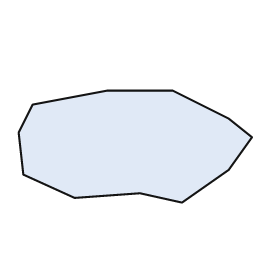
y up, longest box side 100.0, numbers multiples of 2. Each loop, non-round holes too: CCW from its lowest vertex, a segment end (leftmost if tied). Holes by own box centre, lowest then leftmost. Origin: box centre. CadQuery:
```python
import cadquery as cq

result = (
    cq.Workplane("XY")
    .moveTo(20.0, -24.0)
    .lineTo(40.0, -10.0)
    .lineTo(50.0, 4.0)
    .lineTo(40.0, 12.0)
    .lineTo(16.0, 24.0)
    .lineTo(-12.0, 24.0)
    .lineTo(-44.0, 18.0)
    .lineTo(-50.0, 6.0)
    .lineTo(-48.0, -12.0)
    .lineTo(-26.0, -22.0)
    .lineTo(2.0, -20.0)
    .close()
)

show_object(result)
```